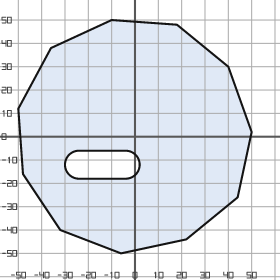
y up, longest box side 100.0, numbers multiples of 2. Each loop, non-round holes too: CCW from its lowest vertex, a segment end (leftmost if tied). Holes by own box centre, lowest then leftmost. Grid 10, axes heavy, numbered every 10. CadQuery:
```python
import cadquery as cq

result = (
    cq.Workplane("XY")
    .moveTo(-6.0, -50.0)
    .lineTo(22.0, -44.0)
    .lineTo(44.0, -26.0)
    .lineTo(50.0, 2.0)
    .lineTo(40.0, 30.0)
    .lineTo(18.0, 48.0)
    .lineTo(-10.0, 50.0)
    .lineTo(-36.0, 38.0)
    .lineTo(-50.0, 12.0)
    .lineTo(-48.0, -16.0)
    .lineTo(-32.0, -40.0)
    .close()
    .moveTo(-24.0, -18.0)
    .lineTo(-4.0, -18.0)
    .threePointArc((2.0, -12.0), (-4.0, -6.0))
    .lineTo(-24.0, -6.0)
    .threePointArc((-30.0, -12.0), (-24.0, -18.0))
    .close()
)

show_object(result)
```